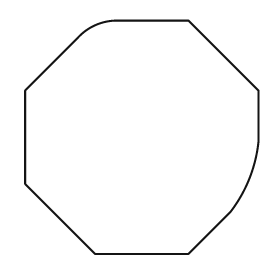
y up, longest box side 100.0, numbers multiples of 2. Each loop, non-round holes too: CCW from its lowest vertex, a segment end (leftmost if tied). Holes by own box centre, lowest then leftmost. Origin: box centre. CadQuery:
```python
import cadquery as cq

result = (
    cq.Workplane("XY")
    .moveTo(-20.0, -50.0)
    .lineTo(20.0, -50.0)
    .lineTo(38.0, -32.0)
    .threePointArc((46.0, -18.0), (50.0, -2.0))
    .lineTo(50.0, 20.0)
    .lineTo(20.0, 50.0)
    .lineTo(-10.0, 50.0)
    .threePointArc((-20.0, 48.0), (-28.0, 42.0))
    .lineTo(-50.0, 20.0)
    .lineTo(-50.0, -20.0)
    .close()
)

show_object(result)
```